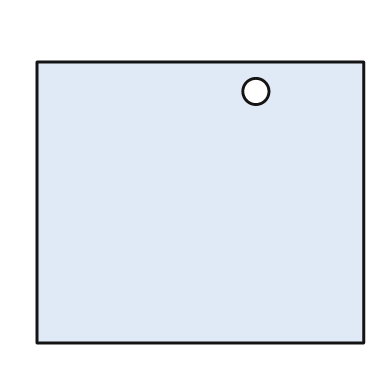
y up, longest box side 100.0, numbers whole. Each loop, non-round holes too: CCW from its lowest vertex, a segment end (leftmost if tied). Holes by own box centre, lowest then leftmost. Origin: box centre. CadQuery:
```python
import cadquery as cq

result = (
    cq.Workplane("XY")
    .moveTo(-50.0, -43.0)
    .lineTo(50.0, -43.0)
    .lineTo(50.0, 43.0)
    .lineTo(-50.0, 43.0)
    .close()
    .moveTo(17.0, 34.0)
    .circle(4.0)
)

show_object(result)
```